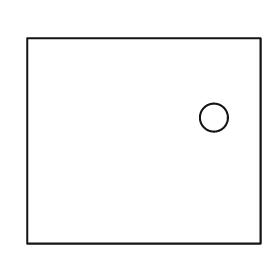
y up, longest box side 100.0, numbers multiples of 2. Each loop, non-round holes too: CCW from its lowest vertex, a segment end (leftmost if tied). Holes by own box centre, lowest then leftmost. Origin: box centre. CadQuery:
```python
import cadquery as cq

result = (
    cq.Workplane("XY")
    .moveTo(-50.0, -44.0)
    .lineTo(50.0, -44.0)
    .lineTo(50.0, 44.0)
    .lineTo(-50.0, 44.0)
    .close()
    .moveTo(30.0, 10.0)
    .circle(6.0)
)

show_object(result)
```